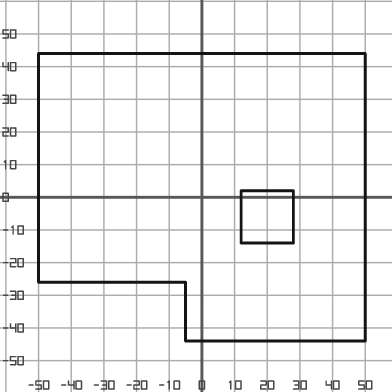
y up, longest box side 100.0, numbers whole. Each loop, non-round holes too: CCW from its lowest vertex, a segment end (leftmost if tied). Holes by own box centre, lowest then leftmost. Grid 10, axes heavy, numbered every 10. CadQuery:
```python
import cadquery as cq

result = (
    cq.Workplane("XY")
    .moveTo(-5.0, -44.0)
    .lineTo(50.0, -44.0)
    .lineTo(50.0, 44.0)
    .lineTo(-50.0, 44.0)
    .lineTo(-50.0, -26.0)
    .lineTo(-5.0, -26.0)
    .close()
    .moveTo(12.0, -14.0)
    .lineTo(28.0, -14.0)
    .lineTo(28.0, 2.0)
    .lineTo(12.0, 2.0)
    .close()
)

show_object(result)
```